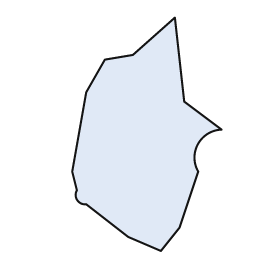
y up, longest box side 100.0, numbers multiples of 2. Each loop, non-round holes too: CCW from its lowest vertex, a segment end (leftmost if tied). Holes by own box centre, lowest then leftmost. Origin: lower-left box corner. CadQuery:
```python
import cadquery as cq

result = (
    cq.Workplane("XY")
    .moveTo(38.0, 0.0)
    .lineTo(46.0, 10.0)
    .lineTo(54.0, 34.0)
    .threePointArc((54.0, 46.0), (64.0, 52.0))
    .lineTo(48.0, 64.0)
    .lineTo(44.0, 100.0)
    .lineTo(26.0, 84.0)
    .lineTo(14.0, 82.0)
    .lineTo(6.0, 68.0)
    .lineTo(0.0, 34.0)
    .lineTo(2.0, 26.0)
    .threePointArc((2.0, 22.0), (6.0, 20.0))
    .lineTo(24.0, 6.0)
    .close()
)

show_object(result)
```